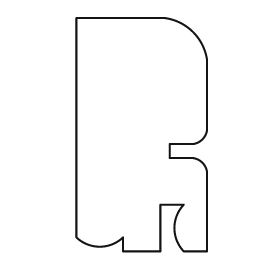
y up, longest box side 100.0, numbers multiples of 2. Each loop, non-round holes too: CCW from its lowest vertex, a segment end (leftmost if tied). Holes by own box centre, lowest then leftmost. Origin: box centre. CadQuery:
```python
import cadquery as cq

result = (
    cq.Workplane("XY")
    .moveTo(-8.0, -50.0)
    .lineTo(8.0, -50.0)
    .lineTo(8.0, -30.0)
    .lineTo(18.0, -30.0)
    .threePointArc((14.0, -40.0), (18.0, -50.0))
    .lineTo(28.0, -50.0)
    .lineTo(28.0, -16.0)
    .threePointArc((26.0, -12.0), (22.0, -10.0))
    .lineTo(12.0, -10.0)
    .lineTo(12.0, -4.0)
    .lineTo(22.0, -4.0)
    .threePointArc((26.0, -2.0), (28.0, 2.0))
    .lineTo(28.0, 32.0)
    .threePointArc((22.0, 44.0), (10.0, 50.0))
    .lineTo(-28.0, 50.0)
    .lineTo(-28.0, -44.0)
    .threePointArc((-18.0, -48.0), (-8.0, -44.0))
    .close()
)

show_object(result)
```